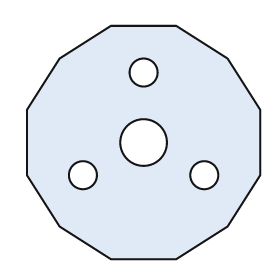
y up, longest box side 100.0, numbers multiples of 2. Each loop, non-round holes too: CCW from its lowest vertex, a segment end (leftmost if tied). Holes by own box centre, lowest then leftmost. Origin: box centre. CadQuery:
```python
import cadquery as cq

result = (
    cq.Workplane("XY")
    .moveTo(-14.0, -50.0)
    .lineTo(14.0, -50.0)
    .lineTo(36.0, -36.0)
    .lineTo(50.0, -14.0)
    .lineTo(50.0, 14.0)
    .lineTo(36.0, 36.0)
    .lineTo(14.0, 50.0)
    .lineTo(-14.0, 50.0)
    .lineTo(-36.0, 36.0)
    .lineTo(-50.0, 14.0)
    .lineTo(-50.0, -14.0)
    .lineTo(-36.0, -36.0)
    .close()
    .moveTo(-26.0, -14.0)
    .circle(6.0)
    .moveTo(26.0, -14.0)
    .circle(6.0)
    .moveTo(0.0, 0.0)
    .circle(10.0)
    .moveTo(0.0, 30.0)
    .circle(6.0)
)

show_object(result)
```